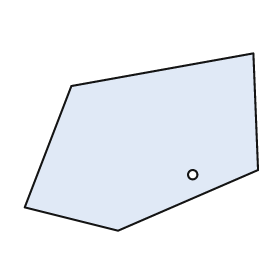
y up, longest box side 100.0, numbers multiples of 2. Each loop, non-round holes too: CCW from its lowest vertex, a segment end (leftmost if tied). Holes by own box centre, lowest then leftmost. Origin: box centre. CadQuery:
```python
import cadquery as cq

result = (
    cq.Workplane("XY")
    .moveTo(-10.0, -38.0)
    .lineTo(50.0, -12.0)
    .lineTo(48.0, 38.0)
    .lineTo(-30.0, 24.0)
    .lineTo(-50.0, -28.0)
    .close()
    .moveTo(22.0, -14.0)
    .circle(2.0)
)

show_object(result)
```